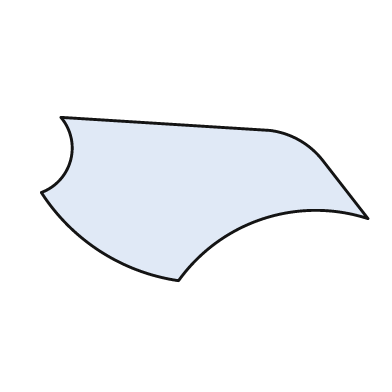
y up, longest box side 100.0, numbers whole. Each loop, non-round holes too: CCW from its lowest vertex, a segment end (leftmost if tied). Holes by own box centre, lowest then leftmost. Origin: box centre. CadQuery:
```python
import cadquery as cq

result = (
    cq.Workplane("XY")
    .moveTo(-8.0, -25.0)
    .threePointArc((18.0, -6.0), (50.0, -6.0))
    .lineTo(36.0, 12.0)
    .threePointArc((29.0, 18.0), (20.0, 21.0))
    .lineTo(-44.0, 25.0)
    .threePointArc((-41.0, 12.0), (-50.0, 2.0))
    .threePointArc((-32.0, -16.0), (-8.0, -25.0))
    .close()
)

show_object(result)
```